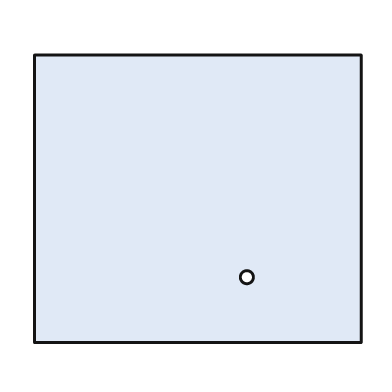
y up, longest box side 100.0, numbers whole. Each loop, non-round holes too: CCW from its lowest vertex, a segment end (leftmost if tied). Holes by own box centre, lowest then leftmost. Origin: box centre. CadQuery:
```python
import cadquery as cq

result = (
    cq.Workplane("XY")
    .moveTo(-50.0, -44.0)
    .lineTo(50.0, -44.0)
    .lineTo(50.0, 44.0)
    .lineTo(-50.0, 44.0)
    .close()
    .moveTo(15.0, -24.0)
    .circle(2.0)
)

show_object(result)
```